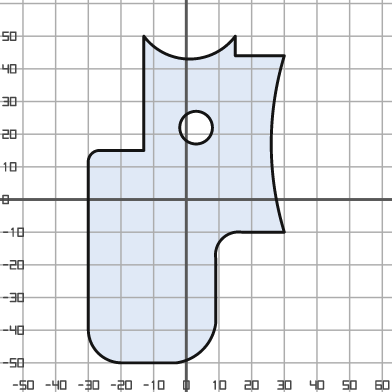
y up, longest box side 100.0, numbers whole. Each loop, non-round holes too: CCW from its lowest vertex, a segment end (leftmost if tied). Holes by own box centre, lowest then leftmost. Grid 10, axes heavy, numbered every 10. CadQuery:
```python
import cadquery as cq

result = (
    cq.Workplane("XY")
    .moveTo(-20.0, -50.0)
    .lineTo(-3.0, -50.0)
    .threePointArc((5.0, -46.0), (9.0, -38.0))
    .lineTo(9.0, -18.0)
    .threePointArc((11.0, -12.0), (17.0, -10.0))
    .lineTo(30.0, -10.0)
    .threePointArc((26.0, 17.0), (30.0, 44.0))
    .lineTo(15.0, 44.0)
    .lineTo(15.0, 50.0)
    .threePointArc((1.0, 43.0), (-13.0, 50.0))
    .lineTo(-13.0, 15.0)
    .lineTo(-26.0, 15.0)
    .threePointArc((-29.0, 14.0), (-30.0, 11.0))
    .lineTo(-30.0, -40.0)
    .threePointArc((-27.0, -47.0), (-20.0, -50.0))
    .close()
    .moveTo(3.0, 22.0)
    .circle(5.0)
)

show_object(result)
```